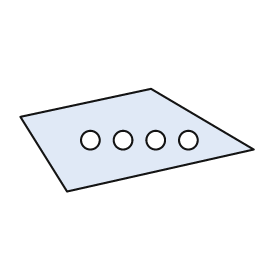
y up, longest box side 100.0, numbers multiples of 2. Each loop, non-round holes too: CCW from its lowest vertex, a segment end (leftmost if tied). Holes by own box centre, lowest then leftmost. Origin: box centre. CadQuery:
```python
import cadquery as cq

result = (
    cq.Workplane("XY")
    .moveTo(-30.0, -22.0)
    .lineTo(50.0, -4.0)
    .lineTo(6.0, 22.0)
    .lineTo(-50.0, 10.0)
    .close()
    .moveTo(-20.0, 0.0)
    .circle(4.0)
    .moveTo(-6.0, 0.0)
    .circle(4.0)
    .moveTo(8.0, 0.0)
    .circle(4.0)
    .moveTo(22.0, 0.0)
    .circle(4.0)
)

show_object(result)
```